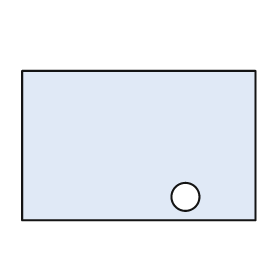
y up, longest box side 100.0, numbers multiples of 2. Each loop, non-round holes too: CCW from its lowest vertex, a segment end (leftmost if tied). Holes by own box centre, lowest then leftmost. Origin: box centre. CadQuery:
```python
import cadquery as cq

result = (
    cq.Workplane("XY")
    .moveTo(-50.0, -32.0)
    .lineTo(50.0, -32.0)
    .lineTo(50.0, 32.0)
    .lineTo(-50.0, 32.0)
    .close()
    .moveTo(20.0, -22.0)
    .circle(6.0)
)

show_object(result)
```